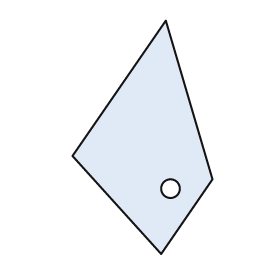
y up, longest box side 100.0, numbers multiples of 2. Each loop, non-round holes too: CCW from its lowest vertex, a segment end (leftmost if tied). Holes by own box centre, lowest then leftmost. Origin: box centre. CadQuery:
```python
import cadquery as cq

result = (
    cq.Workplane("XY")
    .moveTo(8.0, -50.0)
    .lineTo(30.0, -18.0)
    .lineTo(10.0, 50.0)
    .lineTo(-30.0, -8.0)
    .close()
    .moveTo(12.0, -22.0)
    .circle(4.0)
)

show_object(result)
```